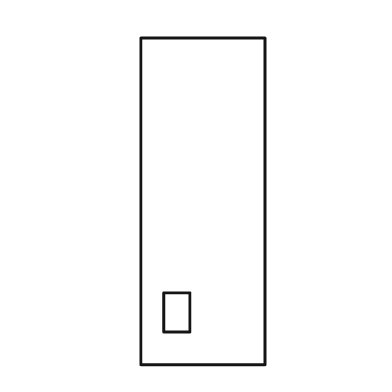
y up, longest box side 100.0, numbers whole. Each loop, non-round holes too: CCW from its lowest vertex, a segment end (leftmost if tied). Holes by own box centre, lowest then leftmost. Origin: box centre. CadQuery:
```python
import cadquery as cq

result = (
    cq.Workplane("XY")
    .moveTo(-19.0, -50.0)
    .lineTo(19.0, -50.0)
    .lineTo(19.0, 50.0)
    .lineTo(-19.0, 50.0)
    .close()
    .moveTo(-12.0, -40.0)
    .lineTo(-4.0, -40.0)
    .lineTo(-4.0, -28.0)
    .lineTo(-12.0, -28.0)
    .close()
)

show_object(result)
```